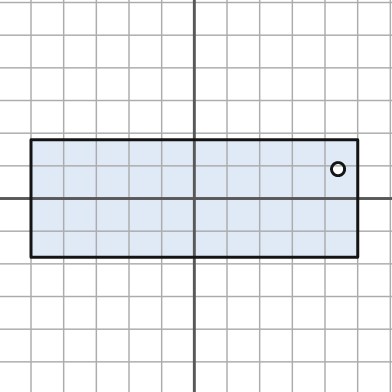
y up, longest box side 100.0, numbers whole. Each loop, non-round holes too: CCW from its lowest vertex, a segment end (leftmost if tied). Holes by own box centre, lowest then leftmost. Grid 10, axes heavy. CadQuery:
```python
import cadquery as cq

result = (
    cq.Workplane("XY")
    .moveTo(-50.0, -18.0)
    .lineTo(50.0, -18.0)
    .lineTo(50.0, 18.0)
    .lineTo(-50.0, 18.0)
    .close()
    .moveTo(44.0, 9.0)
    .circle(2.0)
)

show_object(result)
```